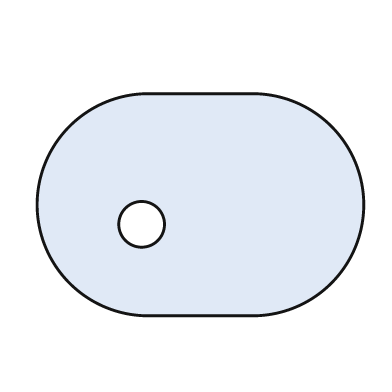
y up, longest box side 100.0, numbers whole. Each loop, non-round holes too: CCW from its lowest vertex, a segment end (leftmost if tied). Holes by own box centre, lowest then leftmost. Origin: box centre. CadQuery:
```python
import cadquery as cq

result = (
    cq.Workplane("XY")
    .moveTo(-16.0, -34.0)
    .lineTo(16.0, -34.0)
    .threePointArc((50.0, 0.0), (16.0, 34.0))
    .lineTo(-16.0, 34.0)
    .threePointArc((-50.0, 0.0), (-16.0, -34.0))
    .close()
    .moveTo(-18.0, -6.0)
    .circle(7.0)
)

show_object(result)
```